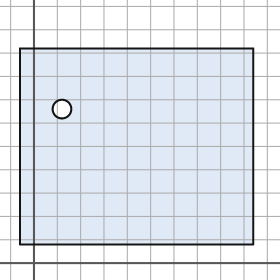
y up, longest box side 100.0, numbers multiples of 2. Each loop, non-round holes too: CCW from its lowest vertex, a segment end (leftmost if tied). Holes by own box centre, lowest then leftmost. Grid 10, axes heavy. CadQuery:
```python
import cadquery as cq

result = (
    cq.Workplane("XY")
    .moveTo(-6.0, 8.0)
    .lineTo(94.0, 8.0)
    .lineTo(94.0, 92.0)
    .lineTo(-6.0, 92.0)
    .close()
    .moveTo(12.0, 66.0)
    .circle(4.0)
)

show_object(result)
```